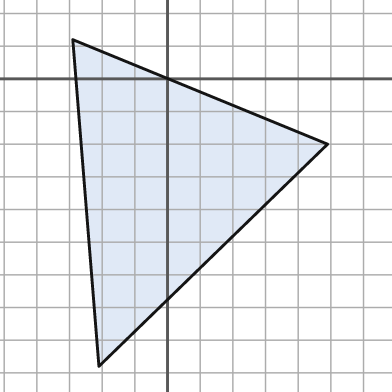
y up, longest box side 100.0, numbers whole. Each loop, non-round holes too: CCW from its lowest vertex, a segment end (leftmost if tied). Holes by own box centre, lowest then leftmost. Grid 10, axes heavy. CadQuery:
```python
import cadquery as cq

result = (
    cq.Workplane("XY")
    .moveTo(-21.0, -88.0)
    .lineTo(49.0, -20.0)
    .lineTo(-29.0, 12.0)
    .close()
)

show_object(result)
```